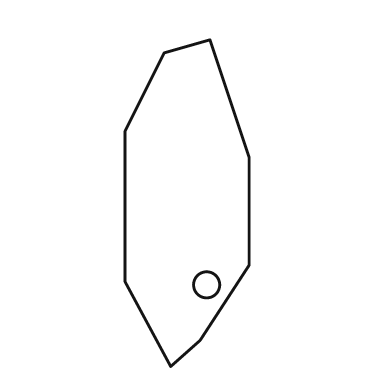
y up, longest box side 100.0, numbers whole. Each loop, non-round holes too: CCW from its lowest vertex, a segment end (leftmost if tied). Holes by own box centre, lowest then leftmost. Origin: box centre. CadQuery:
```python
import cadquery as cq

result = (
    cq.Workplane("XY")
    .moveTo(-5.0, -50.0)
    .lineTo(4.0, -42.0)
    .lineTo(19.0, -19.0)
    .lineTo(19.0, 14.0)
    .lineTo(7.0, 50.0)
    .lineTo(-7.0, 46.0)
    .lineTo(-19.0, 22.0)
    .lineTo(-19.0, -24.0)
    .close()
    .moveTo(6.0, -25.0)
    .circle(4.0)
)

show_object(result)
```